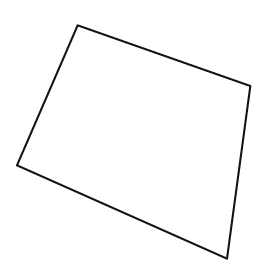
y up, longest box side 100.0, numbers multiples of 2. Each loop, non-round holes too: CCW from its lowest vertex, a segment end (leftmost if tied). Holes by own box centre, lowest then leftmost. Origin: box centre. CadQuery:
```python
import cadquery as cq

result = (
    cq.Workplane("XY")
    .moveTo(40.0, -50.0)
    .lineTo(50.0, 24.0)
    .lineTo(-24.0, 50.0)
    .lineTo(-50.0, -10.0)
    .close()
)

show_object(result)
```